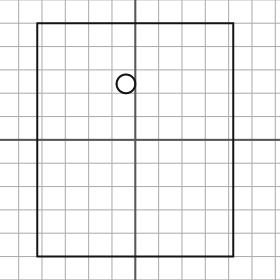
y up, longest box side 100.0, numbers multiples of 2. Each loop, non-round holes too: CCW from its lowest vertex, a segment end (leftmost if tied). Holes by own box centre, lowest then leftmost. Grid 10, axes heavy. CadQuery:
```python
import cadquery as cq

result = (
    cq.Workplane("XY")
    .moveTo(-42.0, -50.0)
    .lineTo(42.0, -50.0)
    .lineTo(42.0, 50.0)
    .lineTo(-42.0, 50.0)
    .close()
    .moveTo(-4.0, 24.0)
    .circle(4.0)
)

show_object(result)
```